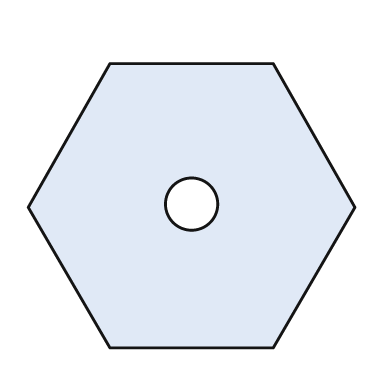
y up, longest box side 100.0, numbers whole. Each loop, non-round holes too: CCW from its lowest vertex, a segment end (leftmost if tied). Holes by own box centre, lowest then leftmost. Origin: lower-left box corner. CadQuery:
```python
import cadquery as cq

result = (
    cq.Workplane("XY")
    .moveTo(25.0, 0.0)
    .lineTo(75.0, 0.0)
    .lineTo(100.0, 43.0)
    .lineTo(75.0, 87.0)
    .lineTo(25.0, 87.0)
    .lineTo(0.0, 43.0)
    .close()
    .moveTo(50.0, 44.0)
    .circle(8.0)
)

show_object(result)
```